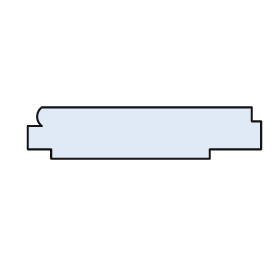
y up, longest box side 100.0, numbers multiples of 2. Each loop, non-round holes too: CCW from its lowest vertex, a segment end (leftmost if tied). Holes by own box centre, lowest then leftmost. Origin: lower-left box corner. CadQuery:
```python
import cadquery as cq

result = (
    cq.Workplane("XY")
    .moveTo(10.0, 0.0)
    .lineTo(78.0, 0.0)
    .lineTo(78.0, 4.0)
    .lineTo(100.0, 4.0)
    .lineTo(100.0, 16.0)
    .lineTo(96.0, 16.0)
    .lineTo(96.0, 22.0)
    .lineTo(6.0, 22.0)
    .threePointArc((4.0, 18.0), (6.0, 14.0))
    .lineTo(0.0, 14.0)
    .lineTo(0.0, 4.0)
    .lineTo(10.0, 4.0)
    .close()
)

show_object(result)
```